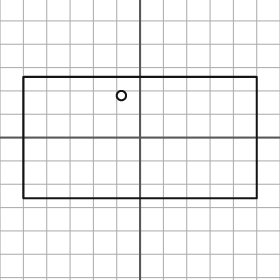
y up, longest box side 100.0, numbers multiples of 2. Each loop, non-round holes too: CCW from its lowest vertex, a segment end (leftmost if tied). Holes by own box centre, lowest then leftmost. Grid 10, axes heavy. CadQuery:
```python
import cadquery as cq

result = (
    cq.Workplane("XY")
    .moveTo(-50.0, -26.0)
    .lineTo(50.0, -26.0)
    .lineTo(50.0, 26.0)
    .lineTo(-50.0, 26.0)
    .close()
    .moveTo(-8.0, 18.0)
    .circle(2.0)
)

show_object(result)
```